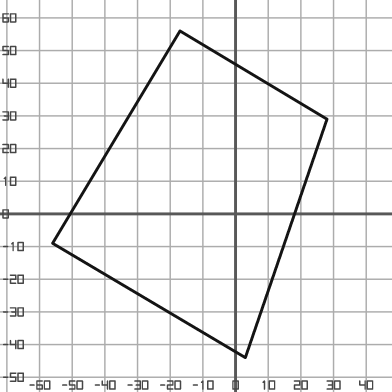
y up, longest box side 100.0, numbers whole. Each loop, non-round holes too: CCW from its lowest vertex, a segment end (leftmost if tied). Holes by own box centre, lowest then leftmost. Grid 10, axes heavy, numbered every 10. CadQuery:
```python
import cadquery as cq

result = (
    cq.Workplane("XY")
    .moveTo(3.0, -44.0)
    .lineTo(28.0, 29.0)
    .lineTo(-17.0, 56.0)
    .lineTo(-56.0, -9.0)
    .close()
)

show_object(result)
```